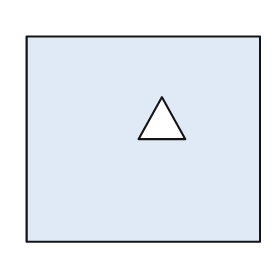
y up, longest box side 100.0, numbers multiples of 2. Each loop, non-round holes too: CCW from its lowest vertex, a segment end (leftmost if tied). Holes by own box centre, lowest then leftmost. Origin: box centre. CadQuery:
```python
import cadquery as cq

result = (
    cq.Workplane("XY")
    .moveTo(-50.0, -44.0)
    .lineTo(50.0, -44.0)
    .lineTo(50.0, 44.0)
    .lineTo(-50.0, 44.0)
    .close()
    .moveTo(-2.0, 0.0)
    .lineTo(18.0, 0.0)
    .lineTo(8.0, 18.0)
    .close()
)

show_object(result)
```